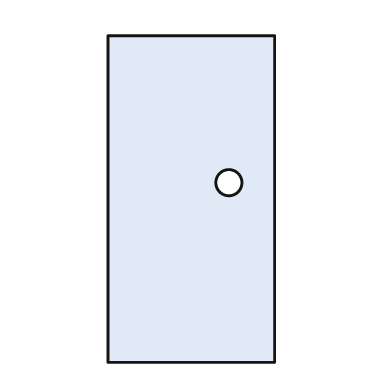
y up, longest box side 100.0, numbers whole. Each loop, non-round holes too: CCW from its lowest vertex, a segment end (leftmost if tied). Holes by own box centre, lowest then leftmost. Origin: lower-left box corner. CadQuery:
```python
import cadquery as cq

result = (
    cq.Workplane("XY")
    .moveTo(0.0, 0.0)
    .lineTo(51.0, 0.0)
    .lineTo(51.0, 100.0)
    .lineTo(0.0, 100.0)
    .close()
    .moveTo(37.0, 55.0)
    .circle(4.0)
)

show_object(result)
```